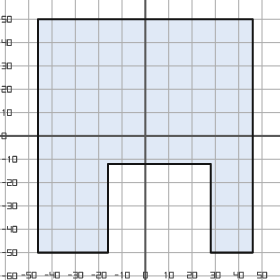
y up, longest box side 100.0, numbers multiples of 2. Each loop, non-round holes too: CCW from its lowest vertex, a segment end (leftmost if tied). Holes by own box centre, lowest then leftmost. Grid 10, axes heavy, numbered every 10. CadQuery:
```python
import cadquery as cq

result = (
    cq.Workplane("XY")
    .moveTo(-46.0, -50.0)
    .lineTo(-16.0, -50.0)
    .lineTo(-16.0, -12.0)
    .lineTo(28.0, -12.0)
    .lineTo(28.0, -50.0)
    .lineTo(46.0, -50.0)
    .lineTo(46.0, 50.0)
    .lineTo(-46.0, 50.0)
    .close()
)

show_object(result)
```